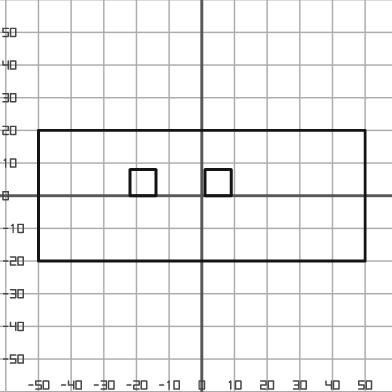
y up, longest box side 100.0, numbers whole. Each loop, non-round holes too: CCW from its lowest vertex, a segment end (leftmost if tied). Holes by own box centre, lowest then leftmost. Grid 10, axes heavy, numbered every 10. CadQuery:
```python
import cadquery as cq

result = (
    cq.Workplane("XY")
    .moveTo(-50.0, -20.0)
    .lineTo(50.0, -20.0)
    .lineTo(50.0, 20.0)
    .lineTo(-50.0, 20.0)
    .close()
    .moveTo(-22.0, 0.0)
    .lineTo(-14.0, 0.0)
    .lineTo(-14.0, 8.0)
    .lineTo(-22.0, 8.0)
    .close()
    .moveTo(1.0, 0.0)
    .lineTo(9.0, 0.0)
    .lineTo(9.0, 8.0)
    .lineTo(1.0, 8.0)
    .close()
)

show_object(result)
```